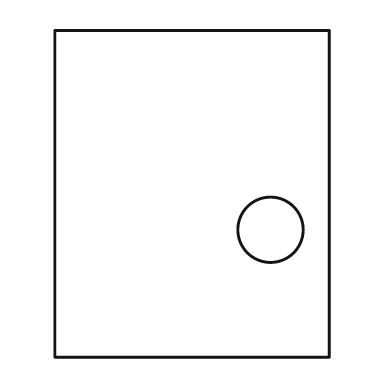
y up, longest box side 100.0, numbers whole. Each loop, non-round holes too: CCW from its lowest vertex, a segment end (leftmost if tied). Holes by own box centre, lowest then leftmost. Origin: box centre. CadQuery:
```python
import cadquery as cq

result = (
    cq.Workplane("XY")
    .moveTo(-42.0, -50.0)
    .lineTo(42.0, -50.0)
    .lineTo(42.0, 50.0)
    .lineTo(-42.0, 50.0)
    .close()
    .moveTo(24.0, -11.0)
    .circle(10.0)
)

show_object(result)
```